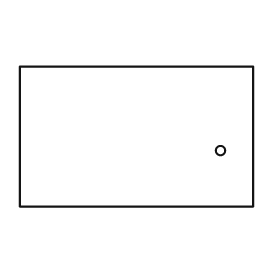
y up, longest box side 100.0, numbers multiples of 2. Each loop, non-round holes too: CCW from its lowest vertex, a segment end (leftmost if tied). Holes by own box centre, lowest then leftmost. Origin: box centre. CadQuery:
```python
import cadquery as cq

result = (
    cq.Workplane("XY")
    .moveTo(-50.0, -30.0)
    .lineTo(50.0, -30.0)
    .lineTo(50.0, 30.0)
    .lineTo(-50.0, 30.0)
    .close()
    .moveTo(36.0, -6.0)
    .circle(2.0)
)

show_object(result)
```